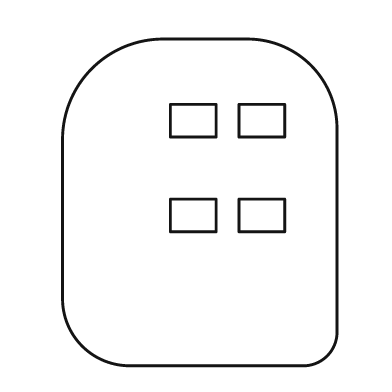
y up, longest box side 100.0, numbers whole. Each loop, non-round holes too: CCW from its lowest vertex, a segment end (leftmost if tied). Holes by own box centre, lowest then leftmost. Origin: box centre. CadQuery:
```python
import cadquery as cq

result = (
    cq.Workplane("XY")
    .moveTo(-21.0, -50.0)
    .lineTo(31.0, -50.0)
    .threePointArc((39.0, -47.0), (42.0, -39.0))
    .lineTo(42.0, 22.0)
    .threePointArc((34.0, 42.0), (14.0, 50.0))
    .lineTo(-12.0, 50.0)
    .threePointArc((-33.0, 41.0), (-42.0, 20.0))
    .lineTo(-42.0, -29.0)
    .threePointArc((-36.0, -44.0), (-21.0, -50.0))
    .close()
    .moveTo(-9.0, -9.0)
    .lineTo(5.0, -9.0)
    .lineTo(5.0, 1.0)
    .lineTo(-9.0, 1.0)
    .close()
    .moveTo(12.0, -9.0)
    .lineTo(26.0, -9.0)
    .lineTo(26.0, 1.0)
    .lineTo(12.0, 1.0)
    .close()
    .moveTo(-9.0, 20.0)
    .lineTo(5.0, 20.0)
    .lineTo(5.0, 30.0)
    .lineTo(-9.0, 30.0)
    .close()
    .moveTo(12.0, 20.0)
    .lineTo(26.0, 20.0)
    .lineTo(26.0, 30.0)
    .lineTo(12.0, 30.0)
    .close()
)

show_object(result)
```